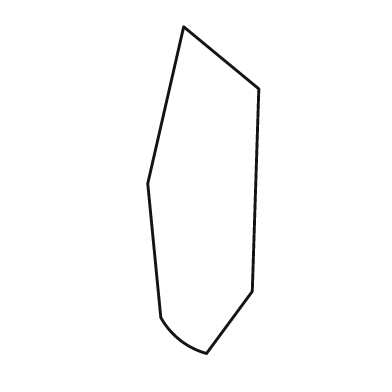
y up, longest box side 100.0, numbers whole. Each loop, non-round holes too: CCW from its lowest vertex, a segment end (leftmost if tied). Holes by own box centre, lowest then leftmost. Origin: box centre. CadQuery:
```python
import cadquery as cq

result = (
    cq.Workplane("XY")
    .moveTo(1.0, -50.0)
    .lineTo(15.0, -31.0)
    .lineTo(17.0, 31.0)
    .lineTo(-6.0, 50.0)
    .lineTo(-17.0, 2.0)
    .lineTo(-13.0, -39.0)
    .threePointArc((-7.0, -46.0), (1.0, -50.0))
    .close()
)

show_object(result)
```